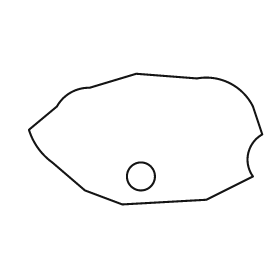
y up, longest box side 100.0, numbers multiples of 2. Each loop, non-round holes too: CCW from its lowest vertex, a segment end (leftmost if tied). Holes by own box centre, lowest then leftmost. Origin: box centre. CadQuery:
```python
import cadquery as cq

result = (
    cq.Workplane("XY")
    .moveTo(-10.0, -28.0)
    .lineTo(26.0, -26.0)
    .lineTo(46.0, -16.0)
    .threePointArc((44.0, -6.0), (50.0, 2.0))
    .lineTo(46.0, 14.0)
    .threePointArc((36.0, 24.0), (22.0, 26.0))
    .lineTo(-4.0, 28.0)
    .lineTo(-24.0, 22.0)
    .threePointArc((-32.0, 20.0), (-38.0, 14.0))
    .lineTo(-50.0, 4.0)
    .threePointArc((-46.0, -4.0), (-40.0, -10.0))
    .lineTo(-26.0, -22.0)
    .close()
    .moveTo(-2.0, -16.0)
    .circle(6.0)
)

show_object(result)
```